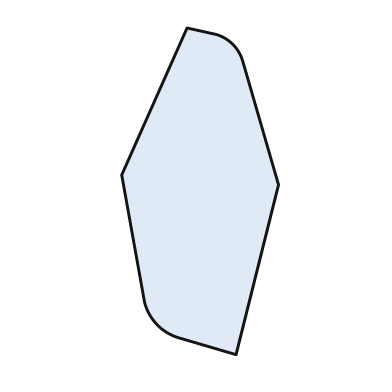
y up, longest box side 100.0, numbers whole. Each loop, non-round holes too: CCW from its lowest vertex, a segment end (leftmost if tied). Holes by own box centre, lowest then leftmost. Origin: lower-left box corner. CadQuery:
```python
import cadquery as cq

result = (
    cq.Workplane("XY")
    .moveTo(35.0, 0.0)
    .lineTo(48.0, 52.0)
    .lineTo(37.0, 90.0)
    .threePointArc((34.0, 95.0), (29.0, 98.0))
    .lineTo(20.0, 100.0)
    .lineTo(0.0, 55.0)
    .lineTo(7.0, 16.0)
    .threePointArc((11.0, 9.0), (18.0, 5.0))
    .close()
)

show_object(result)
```